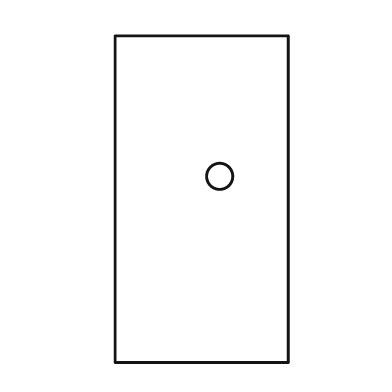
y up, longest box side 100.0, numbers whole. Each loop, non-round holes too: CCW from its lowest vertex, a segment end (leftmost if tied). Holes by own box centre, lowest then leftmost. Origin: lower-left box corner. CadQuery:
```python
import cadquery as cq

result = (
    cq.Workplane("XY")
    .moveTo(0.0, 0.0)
    .lineTo(53.0, 0.0)
    .lineTo(53.0, 100.0)
    .lineTo(0.0, 100.0)
    .close()
    .moveTo(32.0, 57.0)
    .circle(4.0)
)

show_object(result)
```